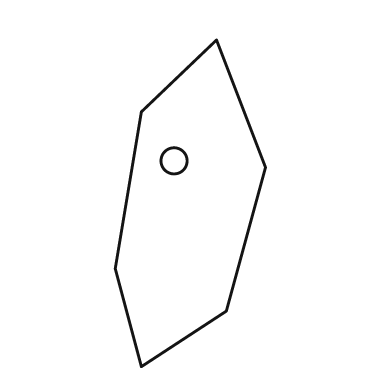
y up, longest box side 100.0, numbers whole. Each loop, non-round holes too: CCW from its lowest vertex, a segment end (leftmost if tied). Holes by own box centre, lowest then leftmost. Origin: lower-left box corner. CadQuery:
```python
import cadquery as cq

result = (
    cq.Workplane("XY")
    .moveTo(8.0, 0.0)
    .lineTo(34.0, 17.0)
    .lineTo(46.0, 61.0)
    .lineTo(31.0, 100.0)
    .lineTo(8.0, 78.0)
    .lineTo(0.0, 30.0)
    .close()
    .moveTo(18.0, 63.0)
    .circle(4.0)
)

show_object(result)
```